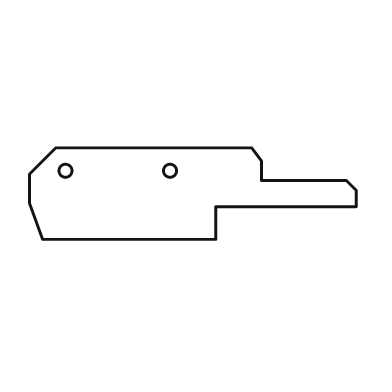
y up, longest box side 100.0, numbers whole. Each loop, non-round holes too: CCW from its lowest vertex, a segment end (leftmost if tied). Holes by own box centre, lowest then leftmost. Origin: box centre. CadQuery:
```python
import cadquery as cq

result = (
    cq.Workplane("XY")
    .moveTo(-46.0, -14.0)
    .lineTo(7.0, -14.0)
    .lineTo(7.0, -4.0)
    .lineTo(50.0, -4.0)
    .lineTo(50.0, 1.0)
    .lineTo(47.0, 4.0)
    .lineTo(21.0, 4.0)
    .lineTo(21.0, 10.0)
    .lineTo(18.0, 14.0)
    .lineTo(-42.0, 14.0)
    .lineTo(-50.0, 6.0)
    .lineTo(-50.0, -3.0)
    .close()
    .moveTo(-39.0, 7.0)
    .circle(2.0)
    .moveTo(-7.0, 7.0)
    .circle(2.0)
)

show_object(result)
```